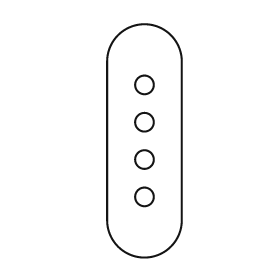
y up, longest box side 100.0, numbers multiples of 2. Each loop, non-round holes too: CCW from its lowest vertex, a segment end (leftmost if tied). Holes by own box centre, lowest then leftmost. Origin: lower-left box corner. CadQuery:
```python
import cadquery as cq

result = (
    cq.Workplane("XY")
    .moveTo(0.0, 16.0)
    .threePointArc((16.0, 0.0), (32.0, 16.0))
    .lineTo(32.0, 84.0)
    .threePointArc((16.0, 100.0), (0.0, 84.0))
    .close()
    .moveTo(16.0, 26.0)
    .circle(4.0)
    .moveTo(16.0, 42.0)
    .circle(4.0)
    .moveTo(16.0, 58.0)
    .circle(4.0)
    .moveTo(16.0, 74.0)
    .circle(4.0)
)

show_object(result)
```